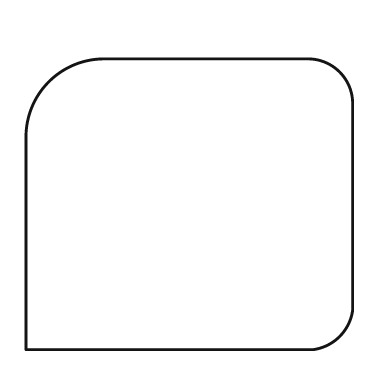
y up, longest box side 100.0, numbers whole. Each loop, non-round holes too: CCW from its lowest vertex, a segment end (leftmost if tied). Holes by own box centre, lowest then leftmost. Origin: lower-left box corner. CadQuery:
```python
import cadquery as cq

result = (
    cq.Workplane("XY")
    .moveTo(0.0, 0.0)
    .lineTo(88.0, 0.0)
    .threePointArc((96.0, 4.0), (100.0, 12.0))
    .lineTo(100.0, 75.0)
    .threePointArc((96.0, 85.0), (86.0, 89.0))
    .lineTo(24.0, 89.0)
    .threePointArc((7.0, 82.0), (0.0, 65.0))
    .close()
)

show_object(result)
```